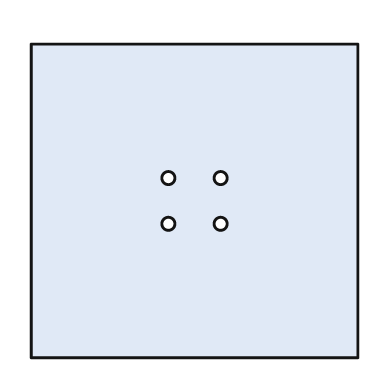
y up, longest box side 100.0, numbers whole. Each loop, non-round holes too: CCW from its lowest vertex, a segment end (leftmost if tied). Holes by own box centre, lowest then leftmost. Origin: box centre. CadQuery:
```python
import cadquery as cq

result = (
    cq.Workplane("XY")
    .moveTo(-50.0, -48.0)
    .lineTo(50.0, -48.0)
    .lineTo(50.0, 48.0)
    .lineTo(-50.0, 48.0)
    .close()
    .moveTo(-8.0, -7.0)
    .circle(2.0)
    .moveTo(8.0, -7.0)
    .circle(2.0)
    .moveTo(-8.0, 7.0)
    .circle(2.0)
    .moveTo(8.0, 7.0)
    .circle(2.0)
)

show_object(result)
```